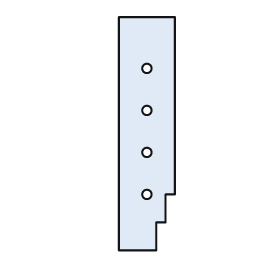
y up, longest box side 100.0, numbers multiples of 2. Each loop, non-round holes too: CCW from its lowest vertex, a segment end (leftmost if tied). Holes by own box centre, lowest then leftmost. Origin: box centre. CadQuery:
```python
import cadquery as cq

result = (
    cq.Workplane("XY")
    .moveTo(-12.0, -50.0)
    .lineTo(4.0, -50.0)
    .lineTo(4.0, -38.0)
    .lineTo(8.0, -38.0)
    .lineTo(8.0, -26.0)
    .lineTo(12.0, -26.0)
    .lineTo(12.0, 50.0)
    .lineTo(-12.0, 50.0)
    .close()
    .moveTo(0.0, -26.0)
    .circle(2.0)
    .moveTo(0.0, -8.0)
    .circle(2.0)
    .moveTo(0.0, 10.0)
    .circle(2.0)
    .moveTo(0.0, 28.0)
    .circle(2.0)
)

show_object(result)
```